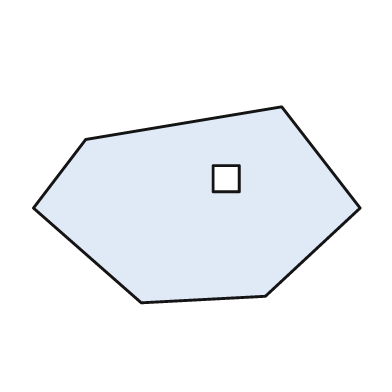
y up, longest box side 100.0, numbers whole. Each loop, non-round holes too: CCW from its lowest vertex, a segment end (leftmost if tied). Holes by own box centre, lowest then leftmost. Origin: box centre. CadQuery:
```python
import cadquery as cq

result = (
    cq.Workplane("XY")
    .moveTo(-17.0, -30.0)
    .lineTo(21.0, -28.0)
    .lineTo(50.0, -1.0)
    .lineTo(26.0, 30.0)
    .lineTo(-34.0, 20.0)
    .lineTo(-50.0, -1.0)
    .close()
    .moveTo(5.0, 4.0)
    .lineTo(13.0, 4.0)
    .lineTo(13.0, 12.0)
    .lineTo(5.0, 12.0)
    .close()
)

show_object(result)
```